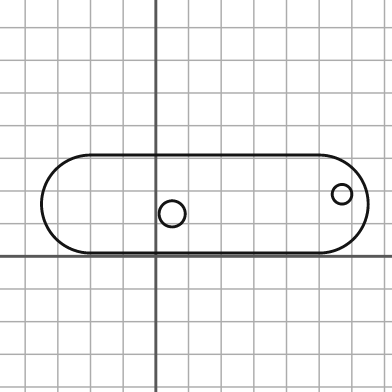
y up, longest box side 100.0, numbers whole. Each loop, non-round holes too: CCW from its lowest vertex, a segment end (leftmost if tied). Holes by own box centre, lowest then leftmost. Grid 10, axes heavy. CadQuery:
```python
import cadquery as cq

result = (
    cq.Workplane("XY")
    .moveTo(-20.0, 1.0)
    .lineTo(50.0, 1.0)
    .threePointArc((65.0, 16.0), (50.0, 31.0))
    .lineTo(-20.0, 31.0)
    .threePointArc((-35.0, 16.0), (-20.0, 1.0))
    .close()
    .moveTo(5.0, 13.0)
    .circle(4.0)
    .moveTo(57.0, 19.0)
    .circle(3.0)
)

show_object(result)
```